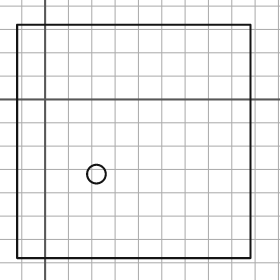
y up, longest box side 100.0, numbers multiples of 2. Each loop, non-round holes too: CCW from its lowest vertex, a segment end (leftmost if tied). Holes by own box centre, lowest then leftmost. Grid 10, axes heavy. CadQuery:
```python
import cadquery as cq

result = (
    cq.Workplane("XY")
    .moveTo(-12.0, -68.0)
    .lineTo(88.0, -68.0)
    .lineTo(88.0, 32.0)
    .lineTo(-12.0, 32.0)
    .close()
    .moveTo(22.0, -32.0)
    .circle(4.0)
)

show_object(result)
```